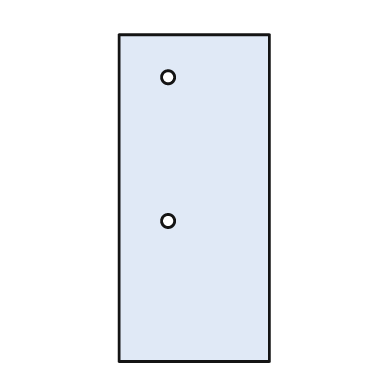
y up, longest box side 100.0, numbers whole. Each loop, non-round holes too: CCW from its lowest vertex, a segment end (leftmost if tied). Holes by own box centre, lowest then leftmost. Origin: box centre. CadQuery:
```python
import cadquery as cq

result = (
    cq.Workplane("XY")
    .moveTo(-23.0, -50.0)
    .lineTo(23.0, -50.0)
    .lineTo(23.0, 50.0)
    .lineTo(-23.0, 50.0)
    .close()
    .moveTo(-8.0, -7.0)
    .circle(2.0)
    .moveTo(-8.0, 37.0)
    .circle(2.0)
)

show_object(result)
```